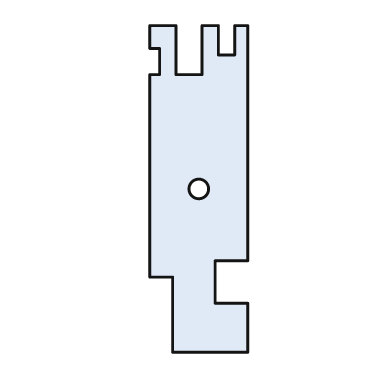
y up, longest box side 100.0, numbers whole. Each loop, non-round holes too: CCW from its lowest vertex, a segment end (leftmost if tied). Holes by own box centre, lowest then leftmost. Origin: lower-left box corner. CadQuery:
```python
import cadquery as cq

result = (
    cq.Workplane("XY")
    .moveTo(7.0, 0.0)
    .lineTo(30.0, 0.0)
    .lineTo(30.0, 15.0)
    .lineTo(20.0, 15.0)
    .lineTo(20.0, 28.0)
    .lineTo(30.0, 28.0)
    .lineTo(30.0, 100.0)
    .lineTo(26.0, 100.0)
    .lineTo(26.0, 91.0)
    .lineTo(21.0, 91.0)
    .lineTo(21.0, 100.0)
    .lineTo(16.0, 100.0)
    .lineTo(16.0, 85.0)
    .lineTo(8.0, 85.0)
    .lineTo(8.0, 100.0)
    .lineTo(0.0, 100.0)
    .lineTo(0.0, 93.0)
    .lineTo(3.0, 93.0)
    .lineTo(3.0, 85.0)
    .lineTo(0.0, 85.0)
    .lineTo(0.0, 23.0)
    .lineTo(7.0, 23.0)
    .close()
    .moveTo(15.0, 50.0)
    .circle(3.0)
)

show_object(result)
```